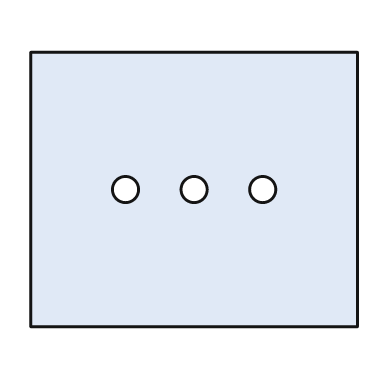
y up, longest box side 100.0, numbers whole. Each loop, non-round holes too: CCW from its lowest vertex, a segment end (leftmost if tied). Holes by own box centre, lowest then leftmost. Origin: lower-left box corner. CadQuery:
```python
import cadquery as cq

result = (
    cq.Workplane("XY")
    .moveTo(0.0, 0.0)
    .lineTo(100.0, 0.0)
    .lineTo(100.0, 84.0)
    .lineTo(0.0, 84.0)
    .close()
    .moveTo(29.0, 42.0)
    .circle(4.0)
    .moveTo(50.0, 42.0)
    .circle(4.0)
    .moveTo(71.0, 42.0)
    .circle(4.0)
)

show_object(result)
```